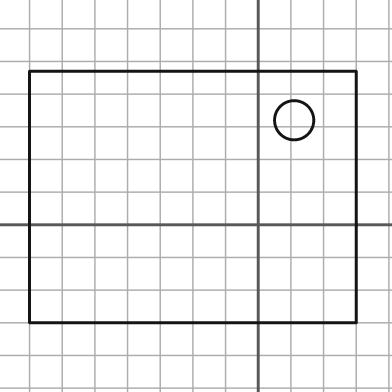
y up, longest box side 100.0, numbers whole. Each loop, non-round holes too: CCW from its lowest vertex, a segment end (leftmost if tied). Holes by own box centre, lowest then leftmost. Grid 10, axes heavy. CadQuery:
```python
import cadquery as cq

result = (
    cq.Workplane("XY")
    .moveTo(-70.0, -30.0)
    .lineTo(30.0, -30.0)
    .lineTo(30.0, 47.0)
    .lineTo(-70.0, 47.0)
    .close()
    .moveTo(11.0, 32.0)
    .circle(6.0)
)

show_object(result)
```